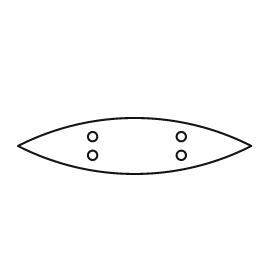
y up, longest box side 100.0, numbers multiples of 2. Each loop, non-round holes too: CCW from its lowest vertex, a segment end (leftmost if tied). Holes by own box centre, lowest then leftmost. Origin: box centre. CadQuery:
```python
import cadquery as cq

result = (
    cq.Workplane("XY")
    .moveTo(-50.0, 0.0)
    .threePointArc((0.0, -12.0), (50.0, 0.0))
    .threePointArc((0.0, 12.0), (-50.0, 0.0))
    .close()
    .moveTo(-18.0, -4.0)
    .circle(2.0)
    .moveTo(20.0, -4.0)
    .circle(2.0)
    .moveTo(-18.0, 4.0)
    .circle(2.0)
    .moveTo(20.0, 4.0)
    .circle(2.0)
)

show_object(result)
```